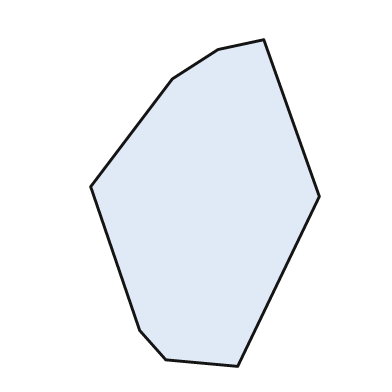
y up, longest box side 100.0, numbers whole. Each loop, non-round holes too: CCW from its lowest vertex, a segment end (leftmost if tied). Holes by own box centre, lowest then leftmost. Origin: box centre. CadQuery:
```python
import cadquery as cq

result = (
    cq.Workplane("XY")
    .moveTo(10.0, -50.0)
    .lineTo(35.0, 2.0)
    .lineTo(18.0, 50.0)
    .lineTo(4.0, 47.0)
    .lineTo(-10.0, 38.0)
    .lineTo(-35.0, 5.0)
    .lineTo(-20.0, -39.0)
    .lineTo(-12.0, -48.0)
    .close()
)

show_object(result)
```